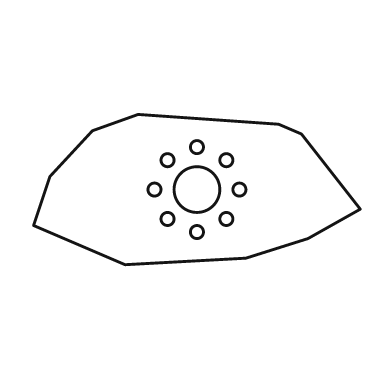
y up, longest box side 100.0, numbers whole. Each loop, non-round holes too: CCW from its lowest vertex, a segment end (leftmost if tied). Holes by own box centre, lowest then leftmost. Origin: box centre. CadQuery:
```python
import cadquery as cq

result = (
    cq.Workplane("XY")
    .moveTo(-22.0, -23.0)
    .lineTo(15.0, -21.0)
    .lineTo(34.0, -15.0)
    .lineTo(50.0, -6.0)
    .lineTo(32.0, 17.0)
    .lineTo(25.0, 20.0)
    .lineTo(-18.0, 23.0)
    .lineTo(-32.0, 18.0)
    .lineTo(-45.0, 4.0)
    .lineTo(-50.0, -11.0)
    .close()
    .moveTo(0.0, -13.0)
    .circle(2.0)
    .moveTo(-9.0, -9.0)
    .circle(2.0)
    .moveTo(9.0, -9.0)
    .circle(2.0)
    .moveTo(-13.0, 0.0)
    .circle(2.0)
    .moveTo(0.0, 0.0)
    .circle(7.0)
    .moveTo(13.0, 0.0)
    .circle(2.0)
    .moveTo(-9.0, 9.0)
    .circle(2.0)
    .moveTo(9.0, 9.0)
    .circle(2.0)
    .moveTo(0.0, 13.0)
    .circle(2.0)
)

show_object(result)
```